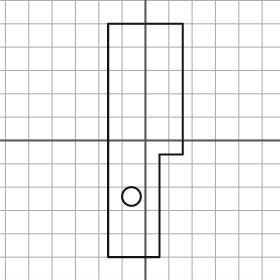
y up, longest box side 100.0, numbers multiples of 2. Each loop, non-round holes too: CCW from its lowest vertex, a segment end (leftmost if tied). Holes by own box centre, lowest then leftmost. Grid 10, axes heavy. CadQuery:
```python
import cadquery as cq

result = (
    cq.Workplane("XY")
    .moveTo(-16.0, -50.0)
    .lineTo(6.0, -50.0)
    .lineTo(6.0, -6.0)
    .lineTo(16.0, -6.0)
    .lineTo(16.0, 50.0)
    .lineTo(-16.0, 50.0)
    .close()
    .moveTo(-6.0, -24.0)
    .circle(4.0)
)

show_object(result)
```